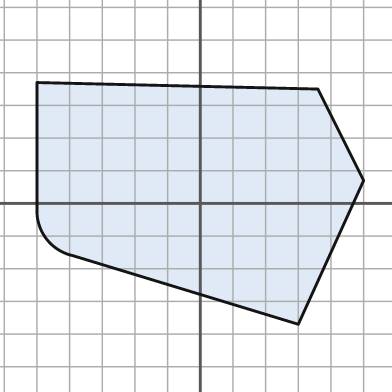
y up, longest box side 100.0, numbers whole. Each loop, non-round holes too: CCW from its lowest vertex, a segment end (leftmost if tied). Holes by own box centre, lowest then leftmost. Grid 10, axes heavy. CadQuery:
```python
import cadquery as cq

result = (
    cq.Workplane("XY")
    .moveTo(30.0, -37.0)
    .lineTo(50.0, 7.0)
    .lineTo(36.0, 35.0)
    .lineTo(-50.0, 37.0)
    .lineTo(-50.0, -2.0)
    .threePointArc((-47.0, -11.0), (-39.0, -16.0))
    .close()
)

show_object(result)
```